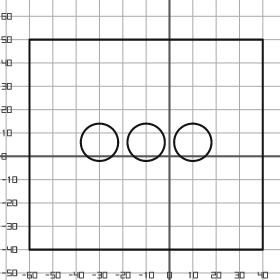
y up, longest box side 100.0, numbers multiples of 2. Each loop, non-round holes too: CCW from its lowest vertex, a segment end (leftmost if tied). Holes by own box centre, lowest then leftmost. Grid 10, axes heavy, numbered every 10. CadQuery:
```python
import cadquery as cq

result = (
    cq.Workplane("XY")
    .moveTo(-60.0, -40.0)
    .lineTo(40.0, -40.0)
    .lineTo(40.0, 50.0)
    .lineTo(-60.0, 50.0)
    .close()
    .moveTo(-30.0, 6.0)
    .circle(8.0)
    .moveTo(-10.0, 6.0)
    .circle(8.0)
    .moveTo(10.0, 6.0)
    .circle(8.0)
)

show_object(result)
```